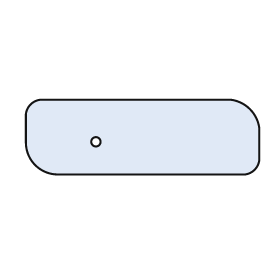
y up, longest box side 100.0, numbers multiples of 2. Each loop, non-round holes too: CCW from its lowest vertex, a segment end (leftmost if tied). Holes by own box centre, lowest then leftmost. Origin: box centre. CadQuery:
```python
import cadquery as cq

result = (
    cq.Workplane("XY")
    .moveTo(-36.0, -16.0)
    .lineTo(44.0, -16.0)
    .threePointArc((48.0, -14.0), (50.0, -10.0))
    .lineTo(50.0, 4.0)
    .threePointArc((46.0, 12.0), (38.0, 16.0))
    .lineTo(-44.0, 16.0)
    .threePointArc((-48.0, 14.0), (-50.0, 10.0))
    .lineTo(-50.0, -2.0)
    .threePointArc((-46.0, -12.0), (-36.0, -16.0))
    .close()
    .moveTo(-20.0, -2.0)
    .circle(2.0)
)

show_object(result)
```